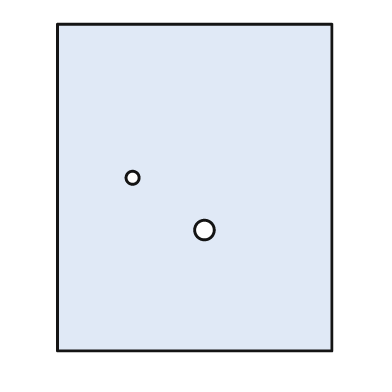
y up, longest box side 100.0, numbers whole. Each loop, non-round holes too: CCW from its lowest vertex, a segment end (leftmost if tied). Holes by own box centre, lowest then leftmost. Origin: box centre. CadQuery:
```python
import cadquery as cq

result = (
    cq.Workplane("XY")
    .moveTo(-42.0, -50.0)
    .lineTo(42.0, -50.0)
    .lineTo(42.0, 50.0)
    .lineTo(-42.0, 50.0)
    .close()
    .moveTo(3.0, -13.0)
    .circle(3.0)
    .moveTo(-19.0, 3.0)
    .circle(2.0)
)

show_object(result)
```